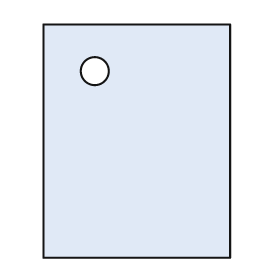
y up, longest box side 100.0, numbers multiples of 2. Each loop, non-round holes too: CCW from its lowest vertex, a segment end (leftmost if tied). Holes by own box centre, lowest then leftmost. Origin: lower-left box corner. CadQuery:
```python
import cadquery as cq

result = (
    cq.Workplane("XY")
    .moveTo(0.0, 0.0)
    .lineTo(80.0, 0.0)
    .lineTo(80.0, 100.0)
    .lineTo(0.0, 100.0)
    .close()
    .moveTo(22.0, 80.0)
    .circle(6.0)
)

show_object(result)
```